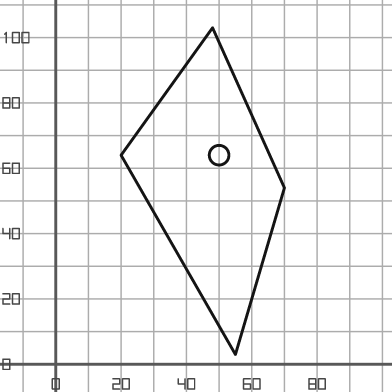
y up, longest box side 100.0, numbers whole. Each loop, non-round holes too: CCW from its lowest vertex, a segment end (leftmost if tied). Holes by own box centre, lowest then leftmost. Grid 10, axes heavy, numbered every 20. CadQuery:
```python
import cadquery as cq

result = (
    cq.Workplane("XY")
    .moveTo(55.0, 3.0)
    .lineTo(70.0, 54.0)
    .lineTo(48.0, 103.0)
    .lineTo(20.0, 64.0)
    .close()
    .moveTo(50.0, 64.0)
    .circle(3.0)
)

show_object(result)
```